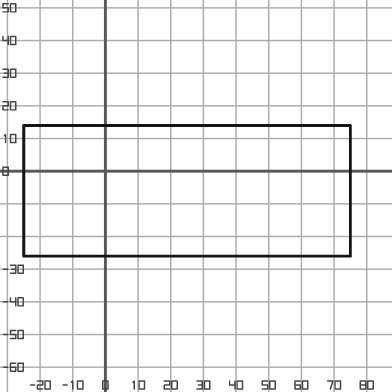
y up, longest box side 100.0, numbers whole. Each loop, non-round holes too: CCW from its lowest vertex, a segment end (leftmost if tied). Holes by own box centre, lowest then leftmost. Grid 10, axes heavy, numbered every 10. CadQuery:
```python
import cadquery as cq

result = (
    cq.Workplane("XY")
    .moveTo(-25.0, -26.0)
    .lineTo(75.0, -26.0)
    .lineTo(75.0, 14.0)
    .lineTo(-25.0, 14.0)
    .close()
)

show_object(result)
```